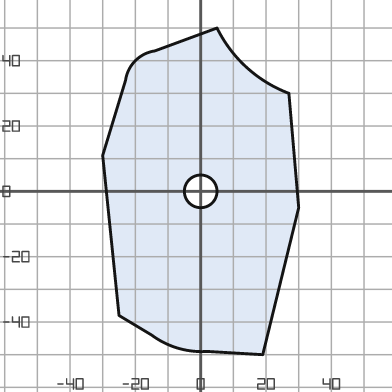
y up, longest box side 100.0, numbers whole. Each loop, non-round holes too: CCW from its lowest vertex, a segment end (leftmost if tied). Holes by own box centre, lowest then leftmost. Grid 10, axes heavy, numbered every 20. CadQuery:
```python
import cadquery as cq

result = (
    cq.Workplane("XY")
    .moveTo(19.0, -50.0)
    .lineTo(30.0, -5.0)
    .lineTo(27.0, 30.0)
    .threePointArc((14.0, 38.0), (5.0, 50.0))
    .lineTo(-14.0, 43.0)
    .threePointArc((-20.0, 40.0), (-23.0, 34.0))
    .lineTo(-30.0, 11.0)
    .lineTo(-25.0, -38.0)
    .lineTo(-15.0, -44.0)
    .threePointArc((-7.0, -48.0), (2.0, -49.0))
    .close()
    .moveTo(0.0, 0.0)
    .circle(5.0)
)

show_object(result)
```